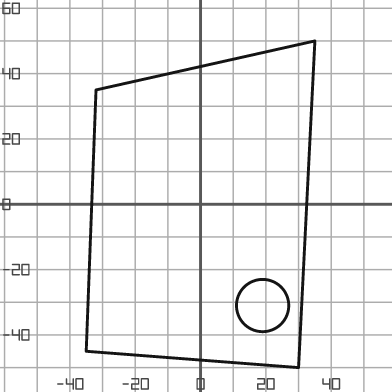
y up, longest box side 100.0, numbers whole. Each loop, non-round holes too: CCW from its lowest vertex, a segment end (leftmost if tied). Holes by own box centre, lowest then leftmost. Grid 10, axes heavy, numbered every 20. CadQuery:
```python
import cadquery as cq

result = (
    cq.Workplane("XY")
    .moveTo(30.0, -50.0)
    .lineTo(35.0, 50.0)
    .lineTo(-32.0, 35.0)
    .lineTo(-35.0, -45.0)
    .close()
    .moveTo(19.0, -31.0)
    .circle(8.0)
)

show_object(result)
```